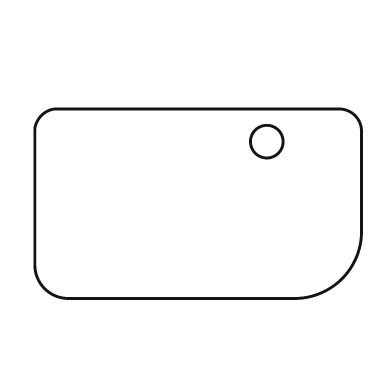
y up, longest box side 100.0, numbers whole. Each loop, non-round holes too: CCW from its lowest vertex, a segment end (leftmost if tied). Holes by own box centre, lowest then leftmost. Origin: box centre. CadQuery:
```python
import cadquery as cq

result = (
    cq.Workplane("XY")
    .moveTo(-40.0, -29.0)
    .lineTo(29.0, -29.0)
    .threePointArc((44.0, -23.0), (50.0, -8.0))
    .lineTo(50.0, 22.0)
    .threePointArc((48.0, 27.0), (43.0, 29.0))
    .lineTo(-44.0, 29.0)
    .threePointArc((-48.0, 27.0), (-50.0, 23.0))
    .lineTo(-50.0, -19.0)
    .threePointArc((-47.0, -26.0), (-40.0, -29.0))
    .close()
    .moveTo(21.0, 19.0)
    .circle(5.0)
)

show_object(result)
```